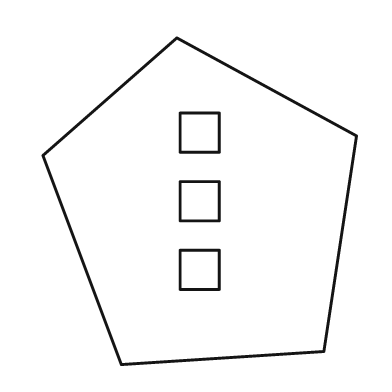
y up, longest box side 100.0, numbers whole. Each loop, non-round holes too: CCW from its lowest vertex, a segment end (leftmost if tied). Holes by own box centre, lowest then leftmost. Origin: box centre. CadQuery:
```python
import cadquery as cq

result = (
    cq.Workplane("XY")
    .moveTo(-24.0, -50.0)
    .lineTo(38.0, -46.0)
    .lineTo(48.0, 20.0)
    .lineTo(-7.0, 50.0)
    .lineTo(-48.0, 14.0)
    .close()
    .moveTo(-6.0, -27.0)
    .lineTo(6.0, -27.0)
    .lineTo(6.0, -15.0)
    .lineTo(-6.0, -15.0)
    .close()
    .moveTo(-6.0, -6.0)
    .lineTo(6.0, -6.0)
    .lineTo(6.0, 6.0)
    .lineTo(-6.0, 6.0)
    .close()
    .moveTo(-6.0, 15.0)
    .lineTo(6.0, 15.0)
    .lineTo(6.0, 27.0)
    .lineTo(-6.0, 27.0)
    .close()
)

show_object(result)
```